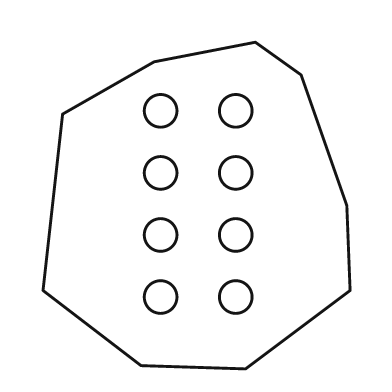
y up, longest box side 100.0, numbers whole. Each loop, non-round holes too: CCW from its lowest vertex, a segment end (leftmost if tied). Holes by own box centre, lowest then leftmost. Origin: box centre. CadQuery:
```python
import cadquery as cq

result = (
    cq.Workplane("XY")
    .moveTo(15.0, -50.0)
    .lineTo(47.0, -26.0)
    .lineTo(46.0, 0.0)
    .lineTo(32.0, 40.0)
    .lineTo(18.0, 50.0)
    .lineTo(-13.0, 44.0)
    .lineTo(-41.0, 28.0)
    .lineTo(-47.0, -26.0)
    .lineTo(-17.0, -49.0)
    .close()
    .moveTo(-11.0, -28.0)
    .circle(5.0)
    .moveTo(12.0, -28.0)
    .circle(5.0)
    .moveTo(-11.0, -9.0)
    .circle(5.0)
    .moveTo(12.0, -9.0)
    .circle(5.0)
    .moveTo(-11.0, 10.0)
    .circle(5.0)
    .moveTo(12.0, 10.0)
    .circle(5.0)
    .moveTo(-11.0, 29.0)
    .circle(5.0)
    .moveTo(12.0, 29.0)
    .circle(5.0)
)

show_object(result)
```